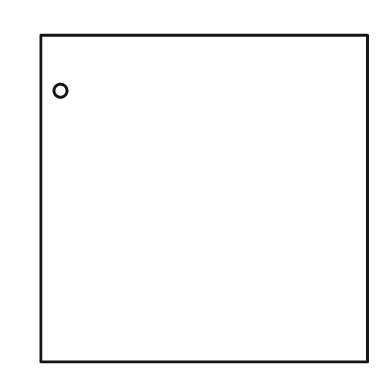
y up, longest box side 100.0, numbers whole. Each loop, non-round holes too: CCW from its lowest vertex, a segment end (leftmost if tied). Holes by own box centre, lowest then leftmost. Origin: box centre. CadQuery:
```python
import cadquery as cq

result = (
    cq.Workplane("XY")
    .moveTo(-50.0, -50.0)
    .lineTo(50.0, -50.0)
    .lineTo(50.0, 50.0)
    .lineTo(-50.0, 50.0)
    .close()
    .moveTo(-44.0, 33.0)
    .circle(2.0)
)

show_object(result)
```